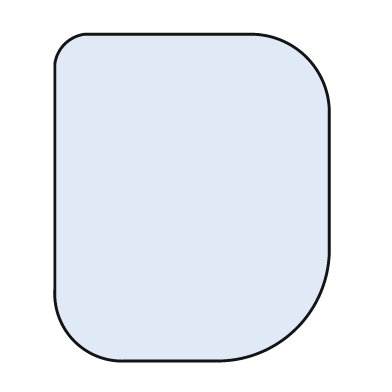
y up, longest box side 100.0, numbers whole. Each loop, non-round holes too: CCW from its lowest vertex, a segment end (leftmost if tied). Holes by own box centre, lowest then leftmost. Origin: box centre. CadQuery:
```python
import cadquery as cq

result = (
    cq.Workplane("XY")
    .moveTo(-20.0, -50.0)
    .lineTo(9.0, -50.0)
    .threePointArc((32.0, -40.0), (42.0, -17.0))
    .lineTo(42.0, 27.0)
    .threePointArc((35.0, 43.0), (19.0, 50.0))
    .lineTo(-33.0, 50.0)
    .threePointArc((-39.0, 47.0), (-42.0, 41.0))
    .lineTo(-42.0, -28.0)
    .threePointArc((-36.0, -44.0), (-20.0, -50.0))
    .close()
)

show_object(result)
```